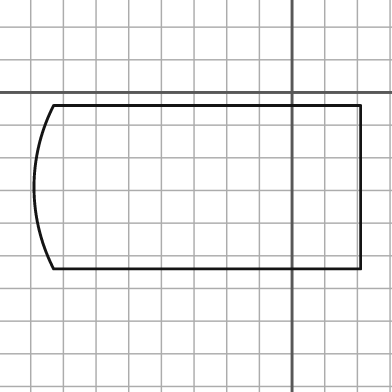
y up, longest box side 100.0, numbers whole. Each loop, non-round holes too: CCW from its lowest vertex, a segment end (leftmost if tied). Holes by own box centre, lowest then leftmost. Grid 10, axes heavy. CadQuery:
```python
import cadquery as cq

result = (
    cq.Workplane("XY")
    .moveTo(-73.0, -54.0)
    .lineTo(21.0, -54.0)
    .lineTo(21.0, -4.0)
    .lineTo(-73.0, -4.0)
    .threePointArc((-79.0, -29.0), (-73.0, -54.0))
    .close()
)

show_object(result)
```